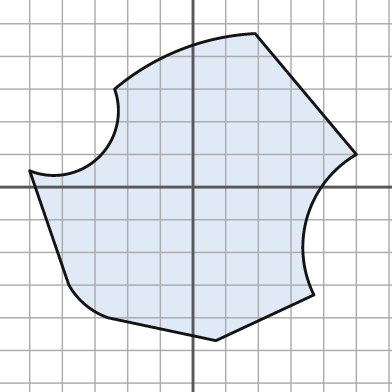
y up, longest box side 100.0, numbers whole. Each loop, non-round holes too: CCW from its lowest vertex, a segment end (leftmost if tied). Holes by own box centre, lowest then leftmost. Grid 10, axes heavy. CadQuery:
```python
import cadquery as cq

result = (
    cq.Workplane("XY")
    .moveTo(7.0, -47.0)
    .lineTo(37.0, -33.0)
    .threePointArc((35.0, -9.0), (50.0, 10.0))
    .lineTo(19.0, 47.0)
    .threePointArc((-4.0, 42.0), (-24.0, 30.0))
    .threePointArc((-29.0, 9.0), (-50.0, 5.0))
    .lineTo(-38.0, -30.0)
    .threePointArc((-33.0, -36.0), (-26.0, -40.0))
    .close()
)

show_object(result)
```